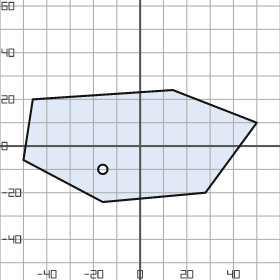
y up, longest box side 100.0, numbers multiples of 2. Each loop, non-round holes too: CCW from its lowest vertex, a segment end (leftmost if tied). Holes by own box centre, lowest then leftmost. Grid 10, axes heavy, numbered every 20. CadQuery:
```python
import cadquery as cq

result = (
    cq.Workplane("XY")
    .moveTo(-16.0, -24.0)
    .lineTo(28.0, -20.0)
    .lineTo(50.0, 10.0)
    .lineTo(14.0, 24.0)
    .lineTo(-46.0, 20.0)
    .lineTo(-50.0, -6.0)
    .close()
    .moveTo(-16.0, -10.0)
    .circle(2.0)
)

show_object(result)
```